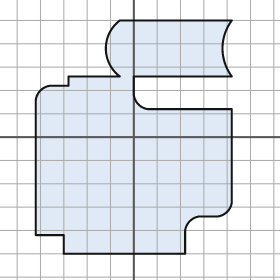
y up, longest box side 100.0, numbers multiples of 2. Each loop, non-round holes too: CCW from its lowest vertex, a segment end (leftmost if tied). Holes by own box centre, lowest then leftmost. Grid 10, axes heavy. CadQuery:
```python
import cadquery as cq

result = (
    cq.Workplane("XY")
    .moveTo(-30.0, -50.0)
    .lineTo(22.0, -50.0)
    .lineTo(22.0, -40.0)
    .threePointArc((24.0, -36.0), (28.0, -34.0))
    .lineTo(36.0, -34.0)
    .threePointArc((40.0, -32.0), (42.0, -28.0))
    .lineTo(42.0, 12.0)
    .lineTo(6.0, 12.0)
    .threePointArc((2.0, 14.0), (0.0, 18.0))
    .lineTo(0.0, 26.0)
    .lineTo(42.0, 26.0)
    .threePointArc((38.0, 38.0), (42.0, 50.0))
    .lineTo(-6.0, 50.0)
    .threePointArc((-12.0, 38.0), (-6.0, 26.0))
    .lineTo(-28.0, 26.0)
    .lineTo(-28.0, 22.0)
    .lineTo(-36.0, 22.0)
    .threePointArc((-40.0, 20.0), (-42.0, 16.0))
    .lineTo(-42.0, -42.0)
    .lineTo(-30.0, -42.0)
    .close()
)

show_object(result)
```